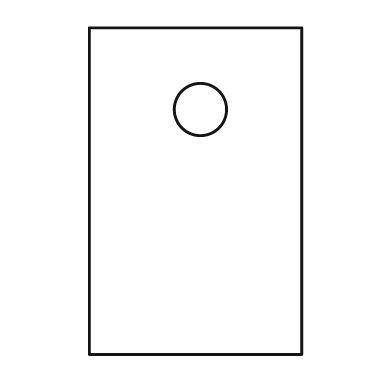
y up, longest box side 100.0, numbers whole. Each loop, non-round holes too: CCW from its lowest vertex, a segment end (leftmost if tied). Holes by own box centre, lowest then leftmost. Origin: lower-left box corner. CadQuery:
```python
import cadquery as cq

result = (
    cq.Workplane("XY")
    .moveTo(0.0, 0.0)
    .lineTo(65.0, 0.0)
    .lineTo(65.0, 100.0)
    .lineTo(0.0, 100.0)
    .close()
    .moveTo(34.0, 75.0)
    .circle(8.0)
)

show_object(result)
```